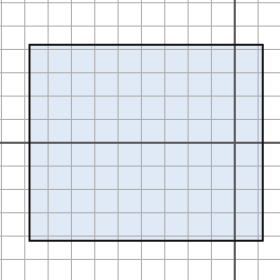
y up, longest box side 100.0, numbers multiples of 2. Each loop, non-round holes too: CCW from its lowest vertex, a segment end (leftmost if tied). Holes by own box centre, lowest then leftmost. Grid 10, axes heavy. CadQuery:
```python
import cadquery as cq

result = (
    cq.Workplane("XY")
    .moveTo(-88.0, -42.0)
    .lineTo(12.0, -42.0)
    .lineTo(12.0, 42.0)
    .lineTo(-88.0, 42.0)
    .close()
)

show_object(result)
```